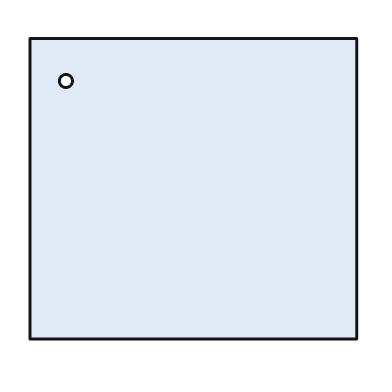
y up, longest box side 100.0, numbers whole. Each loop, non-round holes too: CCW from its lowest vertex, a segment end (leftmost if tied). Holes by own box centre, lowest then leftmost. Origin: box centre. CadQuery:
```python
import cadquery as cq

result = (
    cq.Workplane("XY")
    .moveTo(-50.0, -46.0)
    .lineTo(50.0, -46.0)
    .lineTo(50.0, 46.0)
    .lineTo(-50.0, 46.0)
    .close()
    .moveTo(-39.0, 33.0)
    .circle(2.0)
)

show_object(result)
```